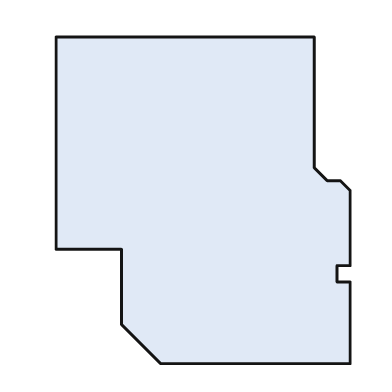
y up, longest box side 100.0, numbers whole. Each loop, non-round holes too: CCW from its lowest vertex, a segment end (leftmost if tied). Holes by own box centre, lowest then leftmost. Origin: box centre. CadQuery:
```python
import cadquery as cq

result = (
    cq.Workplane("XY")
    .moveTo(-13.0, -50.0)
    .lineTo(45.0, -50.0)
    .lineTo(45.0, -25.0)
    .lineTo(41.0, -25.0)
    .lineTo(41.0, -20.0)
    .lineTo(45.0, -20.0)
    .lineTo(45.0, 3.0)
    .lineTo(42.0, 6.0)
    .lineTo(38.0, 6.0)
    .lineTo(34.0, 10.0)
    .lineTo(34.0, 50.0)
    .lineTo(-45.0, 50.0)
    .lineTo(-45.0, -15.0)
    .lineTo(-25.0, -15.0)
    .lineTo(-25.0, -38.0)
    .close()
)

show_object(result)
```